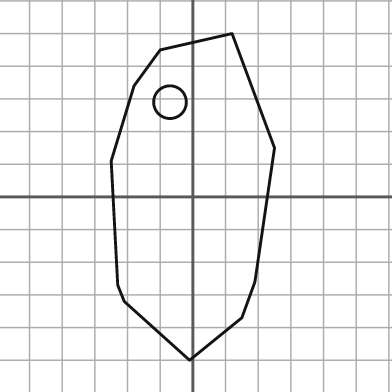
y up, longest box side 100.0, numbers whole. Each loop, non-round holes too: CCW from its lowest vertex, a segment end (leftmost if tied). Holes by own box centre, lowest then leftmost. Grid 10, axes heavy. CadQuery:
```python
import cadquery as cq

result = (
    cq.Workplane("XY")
    .moveTo(-1.0, -50.0)
    .lineTo(15.0, -37.0)
    .lineTo(19.0, -26.0)
    .lineTo(25.0, 15.0)
    .lineTo(12.0, 50.0)
    .lineTo(-10.0, 45.0)
    .lineTo(-18.0, 34.0)
    .lineTo(-25.0, 11.0)
    .lineTo(-23.0, -27.0)
    .lineTo(-21.0, -32.0)
    .close()
    .moveTo(-7.0, 29.0)
    .circle(5.0)
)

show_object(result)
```